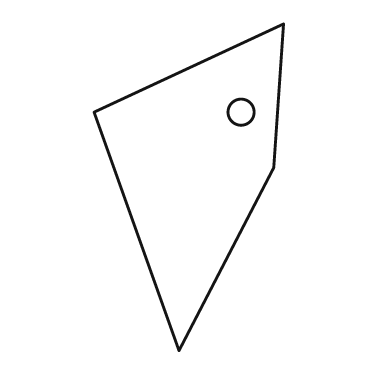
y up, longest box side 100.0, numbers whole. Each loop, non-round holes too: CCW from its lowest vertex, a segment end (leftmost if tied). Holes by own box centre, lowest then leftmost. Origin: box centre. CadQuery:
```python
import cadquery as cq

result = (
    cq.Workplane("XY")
    .moveTo(-3.0, -50.0)
    .lineTo(26.0, 6.0)
    .lineTo(29.0, 50.0)
    .lineTo(-29.0, 23.0)
    .close()
    .moveTo(16.0, 23.0)
    .circle(4.0)
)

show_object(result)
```